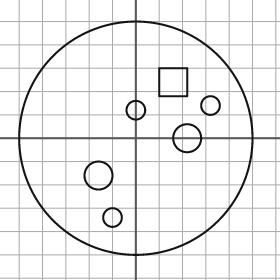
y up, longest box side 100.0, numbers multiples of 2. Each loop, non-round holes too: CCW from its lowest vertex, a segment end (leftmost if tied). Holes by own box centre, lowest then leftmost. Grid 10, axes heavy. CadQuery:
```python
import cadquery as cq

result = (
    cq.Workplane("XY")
    .moveTo(0.0, 0.0)
    .circle(50.0)
    .moveTo(-10.0, -34.0)
    .circle(4.0)
    .moveTo(-16.0, -16.0)
    .circle(6.0)
    .moveTo(22.0, 0.0)
    .circle(6.0)
    .moveTo(0.0, 12.0)
    .circle(4.0)
    .moveTo(32.0, 14.0)
    .circle(4.0)
    .moveTo(10.0, 18.0)
    .lineTo(22.0, 18.0)
    .lineTo(22.0, 30.0)
    .lineTo(10.0, 30.0)
    .close()
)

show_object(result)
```